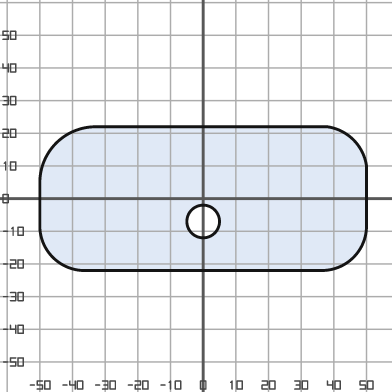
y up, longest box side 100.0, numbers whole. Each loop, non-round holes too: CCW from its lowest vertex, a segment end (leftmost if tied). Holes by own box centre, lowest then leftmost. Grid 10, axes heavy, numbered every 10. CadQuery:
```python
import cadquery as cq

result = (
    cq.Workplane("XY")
    .moveTo(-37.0, -22.0)
    .lineTo(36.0, -22.0)
    .threePointArc((46.0, -18.0), (50.0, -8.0))
    .lineTo(50.0, 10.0)
    .threePointArc((46.0, 18.0), (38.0, 22.0))
    .lineTo(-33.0, 22.0)
    .threePointArc((-45.0, 17.0), (-50.0, 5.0))
    .lineTo(-50.0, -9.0)
    .threePointArc((-46.0, -18.0), (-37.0, -22.0))
    .close()
    .moveTo(0.0, -7.0)
    .circle(5.0)
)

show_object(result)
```